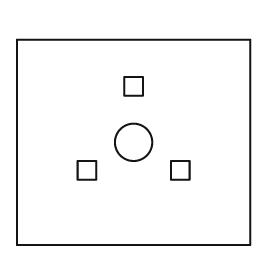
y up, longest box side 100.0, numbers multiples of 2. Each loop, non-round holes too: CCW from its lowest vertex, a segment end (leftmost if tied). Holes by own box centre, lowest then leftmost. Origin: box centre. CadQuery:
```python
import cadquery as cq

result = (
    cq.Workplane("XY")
    .moveTo(-50.0, -44.0)
    .lineTo(50.0, -44.0)
    .lineTo(50.0, 44.0)
    .lineTo(-50.0, 44.0)
    .close()
    .moveTo(-24.0, -16.0)
    .lineTo(-16.0, -16.0)
    .lineTo(-16.0, -8.0)
    .lineTo(-24.0, -8.0)
    .close()
    .moveTo(16.0, -16.0)
    .lineTo(24.0, -16.0)
    .lineTo(24.0, -8.0)
    .lineTo(16.0, -8.0)
    .close()
    .moveTo(0.0, 0.0)
    .circle(8.0)
    .moveTo(-4.0, 20.0)
    .lineTo(4.0, 20.0)
    .lineTo(4.0, 28.0)
    .lineTo(-4.0, 28.0)
    .close()
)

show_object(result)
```